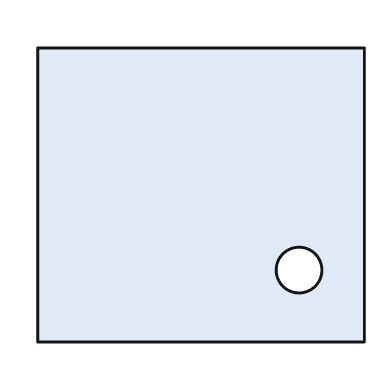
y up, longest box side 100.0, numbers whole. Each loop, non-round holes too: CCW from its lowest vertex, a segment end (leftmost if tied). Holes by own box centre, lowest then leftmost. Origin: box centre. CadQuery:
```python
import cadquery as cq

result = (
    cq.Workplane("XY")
    .moveTo(-50.0, -45.0)
    .lineTo(50.0, -45.0)
    .lineTo(50.0, 45.0)
    .lineTo(-50.0, 45.0)
    .close()
    .moveTo(30.0, -23.0)
    .circle(7.0)
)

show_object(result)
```